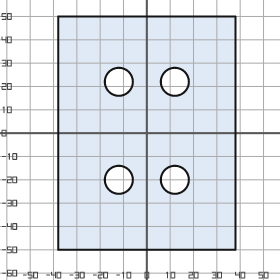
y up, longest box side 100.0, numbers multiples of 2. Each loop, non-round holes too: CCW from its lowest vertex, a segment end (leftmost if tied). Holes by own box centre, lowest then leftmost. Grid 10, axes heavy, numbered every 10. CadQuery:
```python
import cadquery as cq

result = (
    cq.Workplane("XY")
    .moveTo(-38.0, -50.0)
    .lineTo(38.0, -50.0)
    .lineTo(38.0, 50.0)
    .lineTo(-38.0, 50.0)
    .close()
    .moveTo(-12.0, -20.0)
    .circle(6.0)
    .moveTo(12.0, -20.0)
    .circle(6.0)
    .moveTo(-12.0, 22.0)
    .circle(6.0)
    .moveTo(12.0, 22.0)
    .circle(6.0)
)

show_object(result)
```